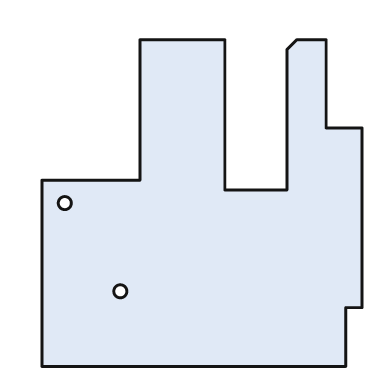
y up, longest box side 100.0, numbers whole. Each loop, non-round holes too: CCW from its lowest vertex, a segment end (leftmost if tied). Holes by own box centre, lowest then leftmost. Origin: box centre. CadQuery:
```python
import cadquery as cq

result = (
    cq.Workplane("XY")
    .moveTo(-49.0, -50.0)
    .lineTo(44.0, -50.0)
    .lineTo(44.0, -32.0)
    .lineTo(49.0, -32.0)
    .lineTo(49.0, 23.0)
    .lineTo(38.0, 23.0)
    .lineTo(38.0, 50.0)
    .lineTo(29.0, 50.0)
    .lineTo(26.0, 47.0)
    .lineTo(26.0, 4.0)
    .lineTo(7.0, 4.0)
    .lineTo(7.0, 50.0)
    .lineTo(-19.0, 50.0)
    .lineTo(-19.0, 7.0)
    .lineTo(-49.0, 7.0)
    .close()
    .moveTo(-25.0, -27.0)
    .circle(2.0)
    .moveTo(-42.0, 0.0)
    .circle(2.0)
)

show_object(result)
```